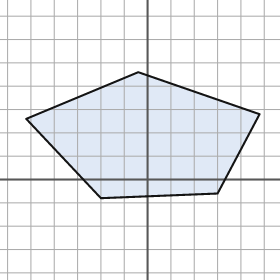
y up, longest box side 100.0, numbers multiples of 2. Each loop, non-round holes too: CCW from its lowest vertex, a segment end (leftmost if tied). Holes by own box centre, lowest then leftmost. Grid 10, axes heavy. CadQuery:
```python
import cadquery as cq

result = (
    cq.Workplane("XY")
    .moveTo(-20.0, -8.0)
    .lineTo(30.0, -6.0)
    .lineTo(48.0, 28.0)
    .lineTo(-4.0, 46.0)
    .lineTo(-52.0, 26.0)
    .close()
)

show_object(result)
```